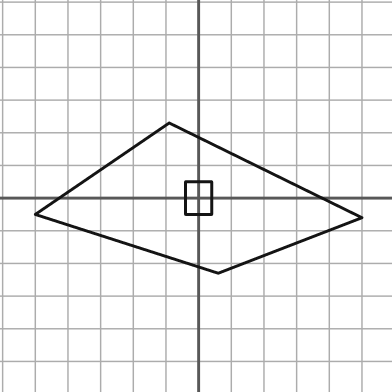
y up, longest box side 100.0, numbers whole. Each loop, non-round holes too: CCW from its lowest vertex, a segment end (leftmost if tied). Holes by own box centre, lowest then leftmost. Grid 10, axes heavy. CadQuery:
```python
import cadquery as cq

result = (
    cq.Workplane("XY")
    .moveTo(6.0, -23.0)
    .lineTo(50.0, -6.0)
    .lineTo(-9.0, 23.0)
    .lineTo(-50.0, -5.0)
    .close()
    .moveTo(-4.0, -5.0)
    .lineTo(4.0, -5.0)
    .lineTo(4.0, 5.0)
    .lineTo(-4.0, 5.0)
    .close()
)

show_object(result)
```